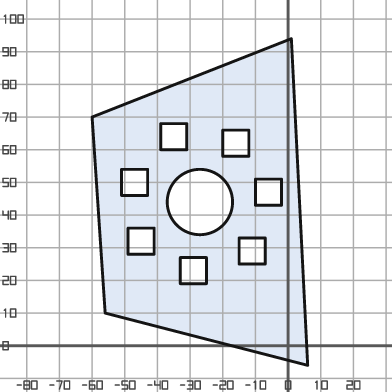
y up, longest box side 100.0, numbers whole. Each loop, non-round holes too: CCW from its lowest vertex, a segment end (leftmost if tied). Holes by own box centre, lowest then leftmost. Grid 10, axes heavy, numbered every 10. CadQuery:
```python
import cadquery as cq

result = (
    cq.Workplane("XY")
    .moveTo(6.0, -6.0)
    .lineTo(1.0, 94.0)
    .lineTo(-60.0, 70.0)
    .lineTo(-56.0, 10.0)
    .close()
    .moveTo(-33.0, 19.0)
    .lineTo(-25.0, 19.0)
    .lineTo(-25.0, 27.0)
    .lineTo(-33.0, 27.0)
    .close()
    .moveTo(-15.0, 25.0)
    .lineTo(-7.0, 25.0)
    .lineTo(-7.0, 33.0)
    .lineTo(-15.0, 33.0)
    .close()
    .moveTo(-49.0, 28.0)
    .lineTo(-41.0, 28.0)
    .lineTo(-41.0, 36.0)
    .lineTo(-49.0, 36.0)
    .close()
    .moveTo(-27.0, 44.0)
    .circle(10.0)
    .moveTo(-10.0, 43.0)
    .lineTo(-2.0, 43.0)
    .lineTo(-2.0, 51.0)
    .lineTo(-10.0, 51.0)
    .close()
    .moveTo(-51.0, 46.0)
    .lineTo(-43.0, 46.0)
    .lineTo(-43.0, 54.0)
    .lineTo(-51.0, 54.0)
    .close()
    .moveTo(-20.0, 58.0)
    .lineTo(-12.0, 58.0)
    .lineTo(-12.0, 66.0)
    .lineTo(-20.0, 66.0)
    .close()
    .moveTo(-39.0, 60.0)
    .lineTo(-31.0, 60.0)
    .lineTo(-31.0, 68.0)
    .lineTo(-39.0, 68.0)
    .close()
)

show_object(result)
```